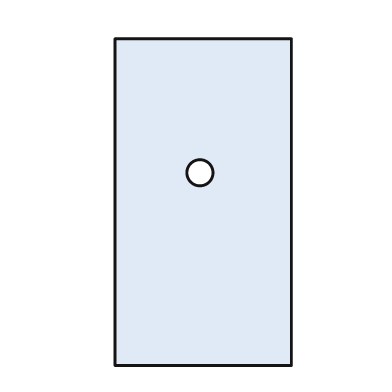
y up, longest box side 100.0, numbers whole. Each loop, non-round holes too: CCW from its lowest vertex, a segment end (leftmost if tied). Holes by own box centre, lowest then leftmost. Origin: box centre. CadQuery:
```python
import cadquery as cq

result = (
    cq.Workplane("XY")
    .moveTo(-27.0, -50.0)
    .lineTo(27.0, -50.0)
    .lineTo(27.0, 50.0)
    .lineTo(-27.0, 50.0)
    .close()
    .moveTo(-1.0, 9.0)
    .circle(4.0)
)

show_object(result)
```